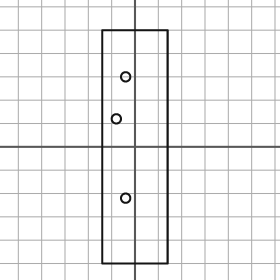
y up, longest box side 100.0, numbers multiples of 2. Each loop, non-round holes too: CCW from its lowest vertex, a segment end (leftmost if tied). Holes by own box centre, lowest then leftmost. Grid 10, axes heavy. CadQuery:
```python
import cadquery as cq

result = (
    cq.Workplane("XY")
    .moveTo(-14.0, -50.0)
    .lineTo(14.0, -50.0)
    .lineTo(14.0, 50.0)
    .lineTo(-14.0, 50.0)
    .close()
    .moveTo(-4.0, -22.0)
    .circle(2.0)
    .moveTo(-8.0, 12.0)
    .circle(2.0)
    .moveTo(-4.0, 30.0)
    .circle(2.0)
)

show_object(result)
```